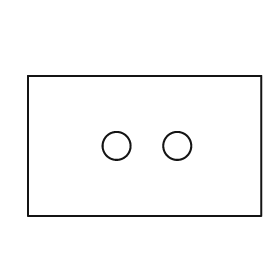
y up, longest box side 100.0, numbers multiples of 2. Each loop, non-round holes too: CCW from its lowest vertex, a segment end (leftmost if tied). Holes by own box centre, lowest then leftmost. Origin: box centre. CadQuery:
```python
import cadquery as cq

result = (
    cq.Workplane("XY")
    .moveTo(-50.0, -30.0)
    .lineTo(50.0, -30.0)
    .lineTo(50.0, 30.0)
    .lineTo(-50.0, 30.0)
    .close()
    .moveTo(-12.0, 0.0)
    .circle(6.0)
    .moveTo(14.0, 0.0)
    .circle(6.0)
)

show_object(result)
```